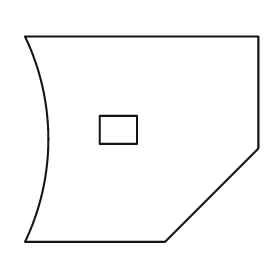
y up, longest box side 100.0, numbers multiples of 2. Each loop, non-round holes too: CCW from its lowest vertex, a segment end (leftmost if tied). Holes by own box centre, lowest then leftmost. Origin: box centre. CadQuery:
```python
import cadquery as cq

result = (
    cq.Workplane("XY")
    .moveTo(-50.0, -44.0)
    .lineTo(10.0, -44.0)
    .lineTo(50.0, -4.0)
    .lineTo(50.0, 44.0)
    .lineTo(-50.0, 44.0)
    .threePointArc((-40.0, 0.0), (-50.0, -44.0))
    .close()
    .moveTo(-18.0, -2.0)
    .lineTo(-2.0, -2.0)
    .lineTo(-2.0, 10.0)
    .lineTo(-18.0, 10.0)
    .close()
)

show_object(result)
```